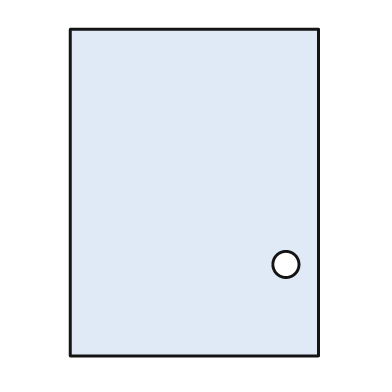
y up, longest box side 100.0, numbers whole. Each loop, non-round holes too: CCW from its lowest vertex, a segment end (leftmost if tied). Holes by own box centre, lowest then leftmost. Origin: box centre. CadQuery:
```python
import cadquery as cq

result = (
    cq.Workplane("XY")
    .moveTo(-38.0, -50.0)
    .lineTo(38.0, -50.0)
    .lineTo(38.0, 50.0)
    .lineTo(-38.0, 50.0)
    .close()
    .moveTo(28.0, -22.0)
    .circle(4.0)
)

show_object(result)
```